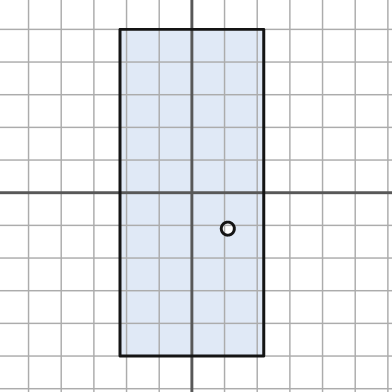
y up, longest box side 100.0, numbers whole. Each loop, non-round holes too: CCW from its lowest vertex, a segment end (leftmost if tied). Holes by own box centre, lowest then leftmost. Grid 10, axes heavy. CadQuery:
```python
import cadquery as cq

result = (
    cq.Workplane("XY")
    .moveTo(-22.0, -50.0)
    .lineTo(22.0, -50.0)
    .lineTo(22.0, 50.0)
    .lineTo(-22.0, 50.0)
    .close()
    .moveTo(11.0, -11.0)
    .circle(2.0)
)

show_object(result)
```